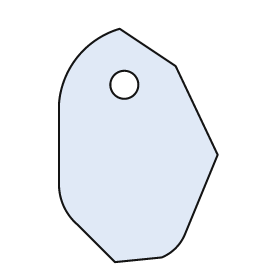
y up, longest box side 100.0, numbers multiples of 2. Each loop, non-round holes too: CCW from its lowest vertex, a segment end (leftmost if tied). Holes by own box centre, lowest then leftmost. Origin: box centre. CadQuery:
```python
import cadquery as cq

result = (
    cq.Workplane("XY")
    .moveTo(-10.0, -50.0)
    .lineTo(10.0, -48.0)
    .threePointArc((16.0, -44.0), (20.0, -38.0))
    .lineTo(34.0, -4.0)
    .lineTo(16.0, 34.0)
    .lineTo(-8.0, 50.0)
    .threePointArc((-26.0, 38.0), (-34.0, 18.0))
    .lineTo(-34.0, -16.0)
    .threePointArc((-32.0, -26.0), (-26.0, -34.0))
    .close()
    .moveTo(-6.0, 26.0)
    .circle(6.0)
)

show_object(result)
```